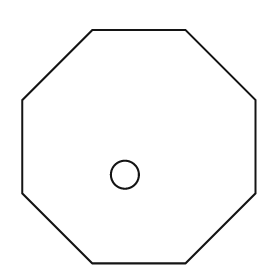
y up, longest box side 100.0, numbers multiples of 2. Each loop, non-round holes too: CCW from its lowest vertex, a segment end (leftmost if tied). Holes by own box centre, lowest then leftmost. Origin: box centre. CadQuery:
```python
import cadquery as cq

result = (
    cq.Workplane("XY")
    .moveTo(-20.0, -50.0)
    .lineTo(20.0, -50.0)
    .lineTo(50.0, -20.0)
    .lineTo(50.0, 20.0)
    .lineTo(20.0, 50.0)
    .lineTo(-20.0, 50.0)
    .lineTo(-50.0, 20.0)
    .lineTo(-50.0, -20.0)
    .close()
    .moveTo(-6.0, -12.0)
    .circle(6.0)
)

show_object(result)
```